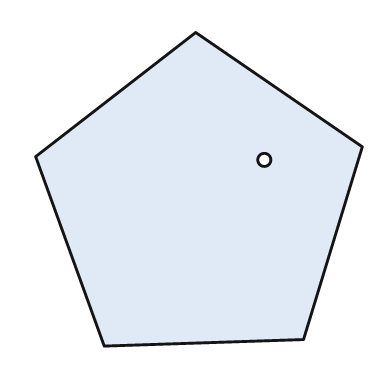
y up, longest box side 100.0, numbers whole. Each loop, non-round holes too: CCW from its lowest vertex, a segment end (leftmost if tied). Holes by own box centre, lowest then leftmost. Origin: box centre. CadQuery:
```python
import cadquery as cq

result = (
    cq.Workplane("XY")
    .moveTo(-29.0, -48.0)
    .lineTo(32.0, -46.0)
    .lineTo(50.0, 13.0)
    .lineTo(-1.0, 48.0)
    .lineTo(-50.0, 10.0)
    .close()
    .moveTo(20.0, 9.0)
    .circle(2.0)
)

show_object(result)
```